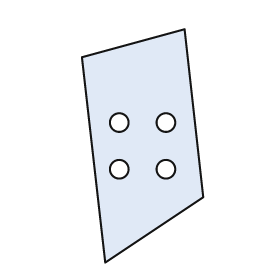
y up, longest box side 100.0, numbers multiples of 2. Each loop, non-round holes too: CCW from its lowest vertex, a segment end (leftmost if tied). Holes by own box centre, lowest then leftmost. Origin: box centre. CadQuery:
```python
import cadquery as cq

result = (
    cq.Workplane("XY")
    .moveTo(-16.0, -50.0)
    .lineTo(26.0, -22.0)
    .lineTo(18.0, 50.0)
    .lineTo(-26.0, 38.0)
    .close()
    .moveTo(-10.0, -10.0)
    .circle(4.0)
    .moveTo(10.0, -10.0)
    .circle(4.0)
    .moveTo(-10.0, 10.0)
    .circle(4.0)
    .moveTo(10.0, 10.0)
    .circle(4.0)
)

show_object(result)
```